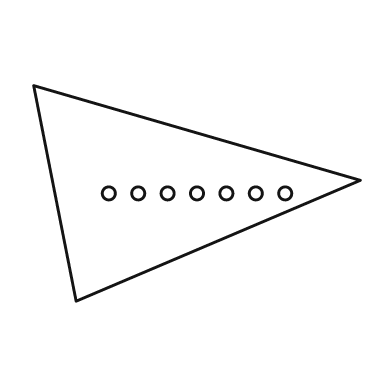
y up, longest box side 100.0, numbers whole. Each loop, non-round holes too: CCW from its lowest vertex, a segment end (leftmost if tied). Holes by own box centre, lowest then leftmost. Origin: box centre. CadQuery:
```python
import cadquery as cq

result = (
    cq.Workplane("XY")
    .moveTo(-37.0, -33.0)
    .lineTo(50.0, 4.0)
    .lineTo(-50.0, 33.0)
    .close()
    .moveTo(-27.0, 0.0)
    .circle(2.0)
    .moveTo(-18.0, 0.0)
    .circle(2.0)
    .moveTo(-9.0, 0.0)
    .circle(2.0)
    .moveTo(0.0, 0.0)
    .circle(2.0)
    .moveTo(9.0, 0.0)
    .circle(2.0)
    .moveTo(18.0, 0.0)
    .circle(2.0)
    .moveTo(27.0, 0.0)
    .circle(2.0)
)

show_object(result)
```